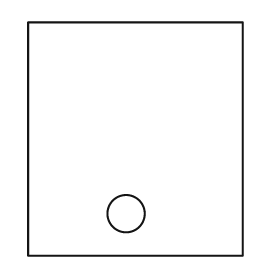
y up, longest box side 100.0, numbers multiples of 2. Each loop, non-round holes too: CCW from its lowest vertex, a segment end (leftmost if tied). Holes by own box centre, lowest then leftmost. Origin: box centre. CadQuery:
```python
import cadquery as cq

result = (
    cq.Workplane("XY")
    .moveTo(-46.0, -50.0)
    .lineTo(46.0, -50.0)
    .lineTo(46.0, 50.0)
    .lineTo(-46.0, 50.0)
    .close()
    .moveTo(-4.0, -32.0)
    .circle(8.0)
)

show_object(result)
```